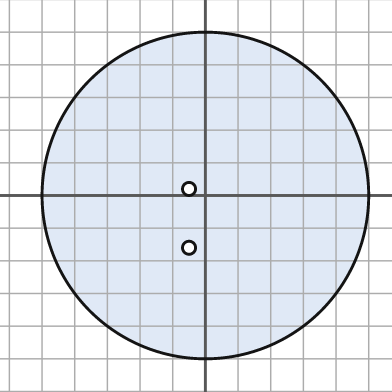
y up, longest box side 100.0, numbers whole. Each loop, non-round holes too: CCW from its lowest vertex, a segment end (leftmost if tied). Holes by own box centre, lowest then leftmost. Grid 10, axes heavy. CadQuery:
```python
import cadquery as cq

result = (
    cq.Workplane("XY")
    .moveTo(0.0, 0.0)
    .circle(50.0)
    .moveTo(-5.0, -16.0)
    .circle(2.0)
    .moveTo(-5.0, 2.0)
    .circle(2.0)
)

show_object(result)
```